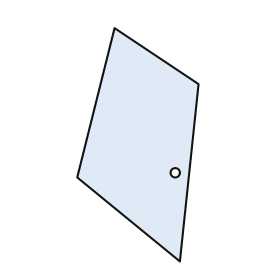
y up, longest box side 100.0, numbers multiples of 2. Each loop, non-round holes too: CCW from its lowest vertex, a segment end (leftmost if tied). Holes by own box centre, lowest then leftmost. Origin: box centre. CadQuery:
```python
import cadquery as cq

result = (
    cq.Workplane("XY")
    .moveTo(18.0, -50.0)
    .lineTo(26.0, 26.0)
    .lineTo(-10.0, 50.0)
    .lineTo(-26.0, -14.0)
    .close()
    .moveTo(16.0, -12.0)
    .circle(2.0)
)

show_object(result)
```